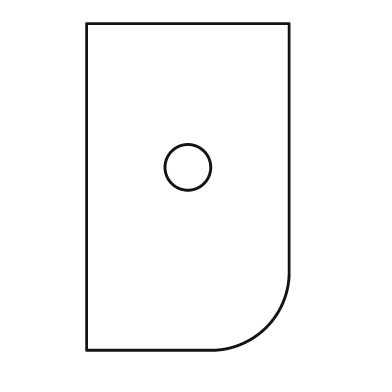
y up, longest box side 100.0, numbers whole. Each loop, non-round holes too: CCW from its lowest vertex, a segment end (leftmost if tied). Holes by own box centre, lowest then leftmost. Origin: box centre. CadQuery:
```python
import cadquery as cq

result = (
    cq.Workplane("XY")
    .moveTo(-31.0, -50.0)
    .lineTo(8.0, -50.0)
    .threePointArc((24.0, -43.0), (31.0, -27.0))
    .lineTo(31.0, 50.0)
    .lineTo(-31.0, 50.0)
    .close()
    .moveTo(0.0, 6.0)
    .circle(7.0)
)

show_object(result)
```